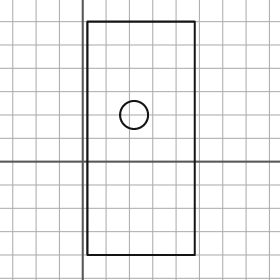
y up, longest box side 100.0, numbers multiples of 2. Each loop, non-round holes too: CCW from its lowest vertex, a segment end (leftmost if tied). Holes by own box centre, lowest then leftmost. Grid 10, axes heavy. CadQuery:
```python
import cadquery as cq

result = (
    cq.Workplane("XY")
    .moveTo(2.0, -40.0)
    .lineTo(48.0, -40.0)
    .lineTo(48.0, 60.0)
    .lineTo(2.0, 60.0)
    .close()
    .moveTo(22.0, 20.0)
    .circle(6.0)
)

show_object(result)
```